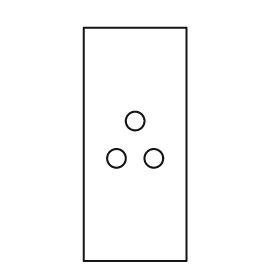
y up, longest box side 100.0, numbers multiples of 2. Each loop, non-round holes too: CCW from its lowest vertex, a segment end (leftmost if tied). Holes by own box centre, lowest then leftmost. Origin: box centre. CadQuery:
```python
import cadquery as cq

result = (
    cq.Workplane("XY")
    .moveTo(-22.0, -50.0)
    .lineTo(22.0, -50.0)
    .lineTo(22.0, 50.0)
    .lineTo(-22.0, 50.0)
    .close()
    .moveTo(-8.0, -6.0)
    .circle(4.0)
    .moveTo(8.0, -6.0)
    .circle(4.0)
    .moveTo(0.0, 10.0)
    .circle(4.0)
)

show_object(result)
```